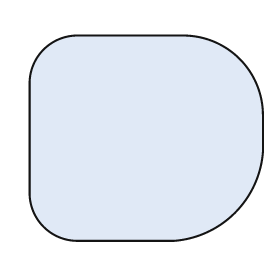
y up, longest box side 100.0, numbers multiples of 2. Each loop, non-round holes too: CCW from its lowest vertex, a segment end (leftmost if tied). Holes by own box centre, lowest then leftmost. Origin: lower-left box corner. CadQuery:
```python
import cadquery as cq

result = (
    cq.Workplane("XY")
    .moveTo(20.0, 0.0)
    .lineTo(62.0, 0.0)
    .threePointArc((88.0, 12.0), (100.0, 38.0))
    .lineTo(100.0, 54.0)
    .threePointArc((90.0, 78.0), (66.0, 88.0))
    .lineTo(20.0, 88.0)
    .threePointArc((6.0, 82.0), (0.0, 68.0))
    .lineTo(0.0, 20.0)
    .threePointArc((6.0, 6.0), (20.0, 0.0))
    .close()
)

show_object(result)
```